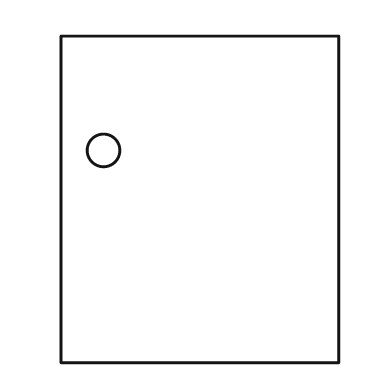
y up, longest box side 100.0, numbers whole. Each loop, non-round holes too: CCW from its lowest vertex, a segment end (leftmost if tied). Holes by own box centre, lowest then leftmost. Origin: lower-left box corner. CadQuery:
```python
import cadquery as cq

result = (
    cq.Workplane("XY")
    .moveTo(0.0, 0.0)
    .lineTo(85.0, 0.0)
    .lineTo(85.0, 100.0)
    .lineTo(0.0, 100.0)
    .close()
    .moveTo(13.0, 65.0)
    .circle(5.0)
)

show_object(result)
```